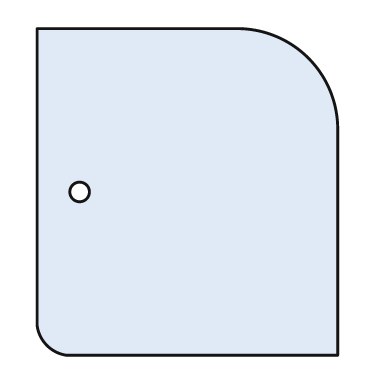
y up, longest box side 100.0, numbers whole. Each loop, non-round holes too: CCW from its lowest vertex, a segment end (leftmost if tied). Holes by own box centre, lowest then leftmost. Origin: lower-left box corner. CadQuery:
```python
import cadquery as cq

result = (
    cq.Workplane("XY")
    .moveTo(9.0, 0.0)
    .lineTo(92.0, 0.0)
    .lineTo(92.0, 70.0)
    .threePointArc((83.0, 91.0), (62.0, 100.0))
    .lineTo(0.0, 100.0)
    .lineTo(0.0, 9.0)
    .threePointArc((3.0, 3.0), (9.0, 0.0))
    .close()
    .moveTo(13.0, 50.0)
    .circle(3.0)
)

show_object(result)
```